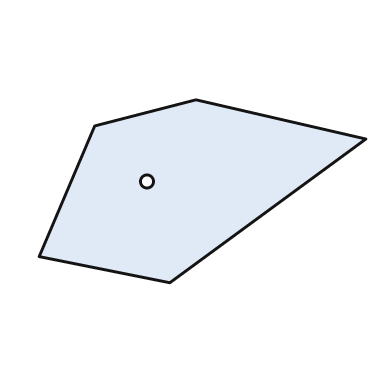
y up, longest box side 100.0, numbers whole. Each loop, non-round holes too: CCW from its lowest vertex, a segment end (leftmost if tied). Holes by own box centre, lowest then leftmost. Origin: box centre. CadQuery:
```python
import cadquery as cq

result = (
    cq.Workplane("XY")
    .moveTo(-10.0, -28.0)
    .lineTo(50.0, 16.0)
    .lineTo(-2.0, 28.0)
    .lineTo(-33.0, 20.0)
    .lineTo(-50.0, -20.0)
    .close()
    .moveTo(-17.0, 3.0)
    .circle(2.0)
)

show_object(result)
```